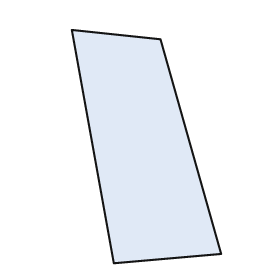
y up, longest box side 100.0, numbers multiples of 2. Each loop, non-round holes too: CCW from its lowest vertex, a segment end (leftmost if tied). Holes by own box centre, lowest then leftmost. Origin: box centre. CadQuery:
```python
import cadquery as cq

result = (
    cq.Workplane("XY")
    .moveTo(-14.0, -50.0)
    .lineTo(32.0, -46.0)
    .lineTo(6.0, 46.0)
    .lineTo(-32.0, 50.0)
    .close()
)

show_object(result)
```